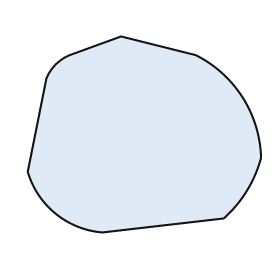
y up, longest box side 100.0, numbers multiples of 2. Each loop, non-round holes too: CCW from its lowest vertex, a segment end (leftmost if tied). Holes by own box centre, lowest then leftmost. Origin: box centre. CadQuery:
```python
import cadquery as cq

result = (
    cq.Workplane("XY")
    .moveTo(-18.0, -42.0)
    .lineTo(34.0, -36.0)
    .threePointArc((44.0, -24.0), (50.0, -10.0))
    .threePointArc((42.0, 16.0), (22.0, 34.0))
    .lineTo(-10.0, 42.0)
    .lineTo(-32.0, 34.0)
    .threePointArc((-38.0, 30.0), (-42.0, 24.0))
    .lineTo(-50.0, -16.0)
    .threePointArc((-38.0, -34.0), (-18.0, -42.0))
    .close()
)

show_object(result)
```